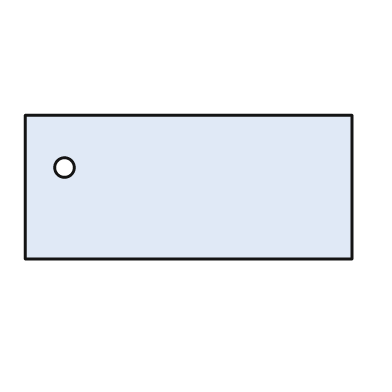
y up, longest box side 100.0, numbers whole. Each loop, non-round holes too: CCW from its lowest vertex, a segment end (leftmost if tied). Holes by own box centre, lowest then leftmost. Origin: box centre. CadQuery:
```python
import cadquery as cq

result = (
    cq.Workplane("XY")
    .moveTo(-50.0, -22.0)
    .lineTo(50.0, -22.0)
    .lineTo(50.0, 22.0)
    .lineTo(-50.0, 22.0)
    .close()
    .moveTo(-38.0, 6.0)
    .circle(3.0)
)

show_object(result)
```